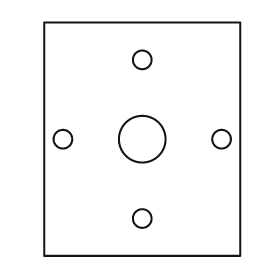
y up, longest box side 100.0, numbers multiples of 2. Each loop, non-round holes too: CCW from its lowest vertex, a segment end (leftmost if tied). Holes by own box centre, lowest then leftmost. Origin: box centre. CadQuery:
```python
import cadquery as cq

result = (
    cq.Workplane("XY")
    .moveTo(-42.0, -50.0)
    .lineTo(42.0, -50.0)
    .lineTo(42.0, 50.0)
    .lineTo(-42.0, 50.0)
    .close()
    .moveTo(0.0, -34.0)
    .circle(4.0)
    .moveTo(-34.0, 0.0)
    .circle(4.0)
    .moveTo(0.0, 0.0)
    .circle(10.0)
    .moveTo(34.0, 0.0)
    .circle(4.0)
    .moveTo(0.0, 34.0)
    .circle(4.0)
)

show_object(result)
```